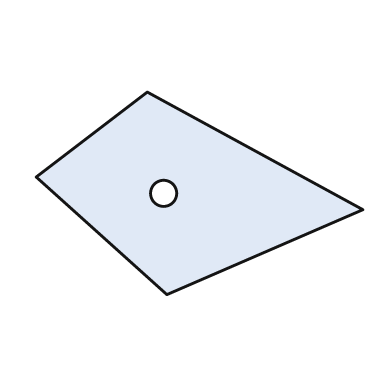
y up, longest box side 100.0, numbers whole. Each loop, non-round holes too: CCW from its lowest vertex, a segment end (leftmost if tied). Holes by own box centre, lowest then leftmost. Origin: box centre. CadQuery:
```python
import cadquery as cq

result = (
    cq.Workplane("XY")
    .moveTo(-10.0, -31.0)
    .lineTo(50.0, -5.0)
    .lineTo(-16.0, 31.0)
    .lineTo(-50.0, 5.0)
    .close()
    .moveTo(-11.0, 0.0)
    .circle(4.0)
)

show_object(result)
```